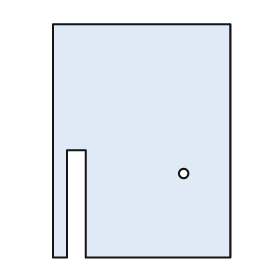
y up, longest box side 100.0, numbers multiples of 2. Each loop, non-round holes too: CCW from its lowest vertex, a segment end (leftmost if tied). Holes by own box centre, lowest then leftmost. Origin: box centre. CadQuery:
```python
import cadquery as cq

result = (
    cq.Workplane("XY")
    .moveTo(-38.0, -50.0)
    .lineTo(-32.0, -50.0)
    .lineTo(-32.0, -4.0)
    .lineTo(-24.0, -4.0)
    .lineTo(-24.0, -50.0)
    .lineTo(38.0, -50.0)
    .lineTo(38.0, 50.0)
    .lineTo(-38.0, 50.0)
    .close()
    .moveTo(18.0, -14.0)
    .circle(2.0)
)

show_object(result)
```